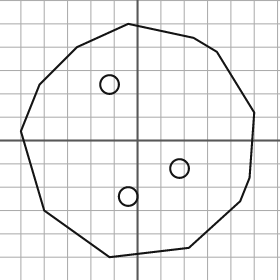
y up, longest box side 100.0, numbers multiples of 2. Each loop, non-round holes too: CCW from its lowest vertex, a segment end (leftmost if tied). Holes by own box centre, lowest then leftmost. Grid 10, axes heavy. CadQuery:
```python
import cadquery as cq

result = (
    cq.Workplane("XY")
    .moveTo(-12.0, -50.0)
    .lineTo(22.0, -46.0)
    .lineTo(44.0, -26.0)
    .lineTo(48.0, -16.0)
    .lineTo(50.0, 12.0)
    .lineTo(34.0, 38.0)
    .lineTo(24.0, 44.0)
    .lineTo(-4.0, 50.0)
    .lineTo(-26.0, 40.0)
    .lineTo(-42.0, 24.0)
    .lineTo(-50.0, 4.0)
    .lineTo(-40.0, -30.0)
    .close()
    .moveTo(-4.0, -24.0)
    .circle(4.0)
    .moveTo(18.0, -12.0)
    .circle(4.0)
    .moveTo(-12.0, 24.0)
    .circle(4.0)
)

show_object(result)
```